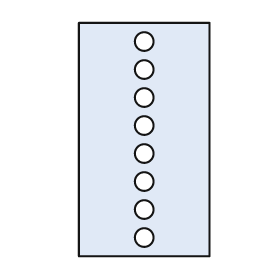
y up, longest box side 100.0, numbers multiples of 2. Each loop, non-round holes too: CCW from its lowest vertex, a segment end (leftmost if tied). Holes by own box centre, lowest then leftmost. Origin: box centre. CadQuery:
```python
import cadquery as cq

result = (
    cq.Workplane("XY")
    .moveTo(-28.0, -50.0)
    .lineTo(28.0, -50.0)
    .lineTo(28.0, 50.0)
    .lineTo(-28.0, 50.0)
    .close()
    .moveTo(0.0, -42.0)
    .circle(4.0)
    .moveTo(0.0, -30.0)
    .circle(4.0)
    .moveTo(0.0, -18.0)
    .circle(4.0)
    .moveTo(0.0, -6.0)
    .circle(4.0)
    .moveTo(0.0, 6.0)
    .circle(4.0)
    .moveTo(0.0, 18.0)
    .circle(4.0)
    .moveTo(0.0, 30.0)
    .circle(4.0)
    .moveTo(0.0, 42.0)
    .circle(4.0)
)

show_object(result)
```